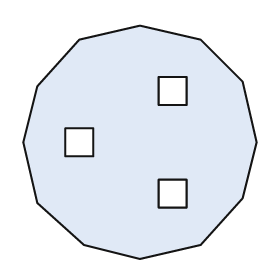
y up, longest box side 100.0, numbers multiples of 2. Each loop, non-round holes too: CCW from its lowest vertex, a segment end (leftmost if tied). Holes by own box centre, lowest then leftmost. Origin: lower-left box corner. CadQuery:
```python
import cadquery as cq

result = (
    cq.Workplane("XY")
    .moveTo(50.0, 0.0)
    .lineTo(76.0, 6.0)
    .lineTo(94.0, 26.0)
    .lineTo(100.0, 50.0)
    .lineTo(94.0, 76.0)
    .lineTo(76.0, 94.0)
    .lineTo(50.0, 100.0)
    .lineTo(24.0, 94.0)
    .lineTo(6.0, 74.0)
    .lineTo(0.0, 50.0)
    .lineTo(6.0, 24.0)
    .lineTo(26.0, 6.0)
    .close()
    .moveTo(58.0, 22.0)
    .lineTo(70.0, 22.0)
    .lineTo(70.0, 34.0)
    .lineTo(58.0, 34.0)
    .close()
    .moveTo(18.0, 44.0)
    .lineTo(30.0, 44.0)
    .lineTo(30.0, 56.0)
    .lineTo(18.0, 56.0)
    .close()
    .moveTo(58.0, 66.0)
    .lineTo(70.0, 66.0)
    .lineTo(70.0, 78.0)
    .lineTo(58.0, 78.0)
    .close()
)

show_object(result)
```